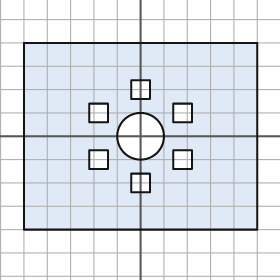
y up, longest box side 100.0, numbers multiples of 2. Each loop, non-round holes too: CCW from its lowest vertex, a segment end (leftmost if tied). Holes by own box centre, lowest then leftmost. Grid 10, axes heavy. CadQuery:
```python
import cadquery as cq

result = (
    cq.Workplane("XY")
    .moveTo(-50.0, -40.0)
    .lineTo(50.0, -40.0)
    .lineTo(50.0, 40.0)
    .lineTo(-50.0, 40.0)
    .close()
    .moveTo(-4.0, -24.0)
    .lineTo(4.0, -24.0)
    .lineTo(4.0, -16.0)
    .lineTo(-4.0, -16.0)
    .close()
    .moveTo(-22.0, -14.0)
    .lineTo(-14.0, -14.0)
    .lineTo(-14.0, -6.0)
    .lineTo(-22.0, -6.0)
    .close()
    .moveTo(14.0, -14.0)
    .lineTo(22.0, -14.0)
    .lineTo(22.0, -6.0)
    .lineTo(14.0, -6.0)
    .close()
    .moveTo(0.0, 0.0)
    .circle(10.0)
    .moveTo(-22.0, 6.0)
    .lineTo(-14.0, 6.0)
    .lineTo(-14.0, 14.0)
    .lineTo(-22.0, 14.0)
    .close()
    .moveTo(14.0, 6.0)
    .lineTo(22.0, 6.0)
    .lineTo(22.0, 14.0)
    .lineTo(14.0, 14.0)
    .close()
    .moveTo(-4.0, 16.0)
    .lineTo(4.0, 16.0)
    .lineTo(4.0, 24.0)
    .lineTo(-4.0, 24.0)
    .close()
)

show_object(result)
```